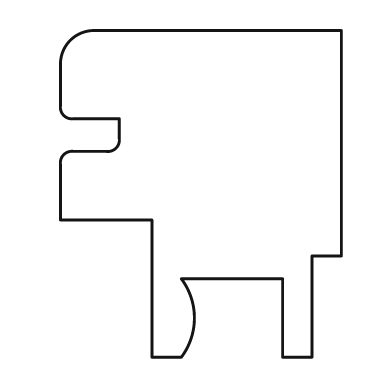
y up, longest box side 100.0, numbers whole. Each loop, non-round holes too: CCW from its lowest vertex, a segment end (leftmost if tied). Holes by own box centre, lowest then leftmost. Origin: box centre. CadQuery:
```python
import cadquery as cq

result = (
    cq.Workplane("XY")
    .moveTo(-15.0, -50.0)
    .lineTo(-6.0, -50.0)
    .threePointArc((-2.0, -38.0), (-6.0, -26.0))
    .lineTo(25.0, -26.0)
    .lineTo(25.0, -50.0)
    .lineTo(34.0, -50.0)
    .lineTo(34.0, -19.0)
    .lineTo(43.0, -19.0)
    .lineTo(43.0, 50.0)
    .lineTo(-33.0, 50.0)
    .threePointArc((-40.0, 47.0), (-43.0, 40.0))
    .lineTo(-43.0, 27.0)
    .threePointArc((-42.0, 24.0), (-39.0, 23.0))
    .lineTo(-25.0, 23.0)
    .lineTo(-25.0, 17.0)
    .threePointArc((-26.0, 14.0), (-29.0, 13.0))
    .lineTo(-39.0, 13.0)
    .threePointArc((-42.0, 12.0), (-43.0, 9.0))
    .lineTo(-43.0, -8.0)
    .lineTo(-15.0, -8.0)
    .close()
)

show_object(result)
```